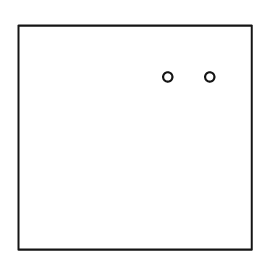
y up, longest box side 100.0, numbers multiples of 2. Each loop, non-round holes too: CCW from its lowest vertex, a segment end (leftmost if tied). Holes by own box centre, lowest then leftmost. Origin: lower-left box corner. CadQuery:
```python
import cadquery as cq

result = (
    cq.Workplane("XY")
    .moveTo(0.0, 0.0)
    .lineTo(100.0, 0.0)
    .lineTo(100.0, 96.0)
    .lineTo(0.0, 96.0)
    .close()
    .moveTo(64.0, 74.0)
    .circle(2.0)
    .moveTo(82.0, 74.0)
    .circle(2.0)
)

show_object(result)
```